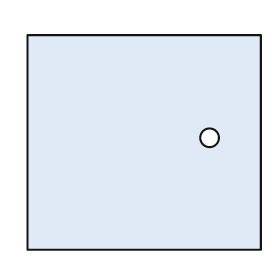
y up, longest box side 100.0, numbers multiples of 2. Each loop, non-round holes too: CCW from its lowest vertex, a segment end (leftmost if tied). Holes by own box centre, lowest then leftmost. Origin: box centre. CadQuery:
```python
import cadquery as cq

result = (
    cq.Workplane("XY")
    .moveTo(-50.0, -46.0)
    .lineTo(50.0, -46.0)
    .lineTo(50.0, 46.0)
    .lineTo(-50.0, 46.0)
    .close()
    .moveTo(28.0, 2.0)
    .circle(4.0)
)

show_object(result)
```